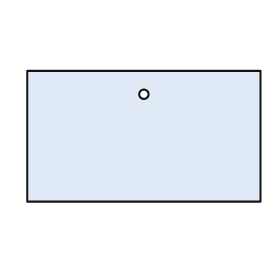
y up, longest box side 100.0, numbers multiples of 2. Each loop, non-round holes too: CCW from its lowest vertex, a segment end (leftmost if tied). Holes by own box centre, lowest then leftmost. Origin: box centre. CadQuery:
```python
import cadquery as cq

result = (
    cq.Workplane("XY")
    .moveTo(-50.0, -28.0)
    .lineTo(50.0, -28.0)
    .lineTo(50.0, 28.0)
    .lineTo(-50.0, 28.0)
    .close()
    .moveTo(0.0, 18.0)
    .circle(2.0)
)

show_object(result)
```